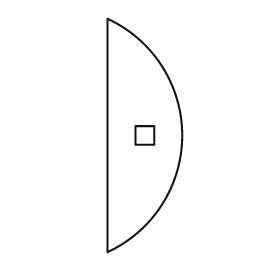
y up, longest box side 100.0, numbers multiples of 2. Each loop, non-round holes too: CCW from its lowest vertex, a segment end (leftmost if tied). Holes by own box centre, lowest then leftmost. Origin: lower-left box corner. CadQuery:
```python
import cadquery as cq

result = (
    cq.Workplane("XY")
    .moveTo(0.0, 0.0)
    .threePointArc((32.0, 50.0), (0.0, 100.0))
    .close()
    .moveTo(12.0, 46.0)
    .lineTo(20.0, 46.0)
    .lineTo(20.0, 54.0)
    .lineTo(12.0, 54.0)
    .close()
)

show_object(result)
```